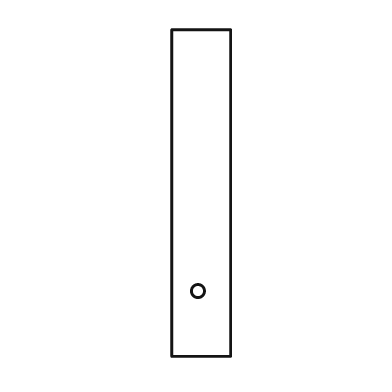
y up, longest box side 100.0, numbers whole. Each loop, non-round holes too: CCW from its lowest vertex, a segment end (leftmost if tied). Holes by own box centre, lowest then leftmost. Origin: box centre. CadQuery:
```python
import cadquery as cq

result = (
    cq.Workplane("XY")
    .moveTo(-9.0, -50.0)
    .lineTo(9.0, -50.0)
    .lineTo(9.0, 50.0)
    .lineTo(-9.0, 50.0)
    .close()
    .moveTo(-1.0, -30.0)
    .circle(2.0)
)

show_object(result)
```